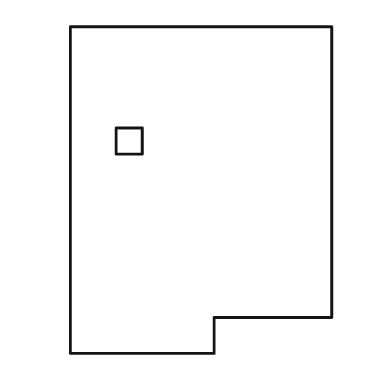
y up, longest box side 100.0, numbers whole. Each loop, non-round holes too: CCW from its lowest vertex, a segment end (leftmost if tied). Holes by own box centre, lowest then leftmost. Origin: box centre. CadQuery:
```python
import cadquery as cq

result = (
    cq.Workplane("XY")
    .moveTo(-40.0, -50.0)
    .lineTo(4.0, -50.0)
    .lineTo(4.0, -39.0)
    .lineTo(40.0, -39.0)
    .lineTo(40.0, 50.0)
    .lineTo(-40.0, 50.0)
    .close()
    .moveTo(-26.0, 11.0)
    .lineTo(-18.0, 11.0)
    .lineTo(-18.0, 19.0)
    .lineTo(-26.0, 19.0)
    .close()
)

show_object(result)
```